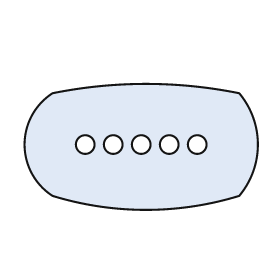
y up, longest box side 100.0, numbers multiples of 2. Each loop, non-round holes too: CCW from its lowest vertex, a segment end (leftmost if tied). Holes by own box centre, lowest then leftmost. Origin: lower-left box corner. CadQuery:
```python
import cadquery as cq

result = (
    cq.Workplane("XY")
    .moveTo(12.0, 6.0)
    .threePointArc((52.0, 0.0), (92.0, 6.0))
    .threePointArc((100.0, 28.0), (92.0, 50.0))
    .threePointArc((52.0, 54.0), (12.0, 50.0))
    .threePointArc((0.0, 28.0), (12.0, 6.0))
    .close()
    .moveTo(26.0, 28.0)
    .circle(4.0)
    .moveTo(38.0, 28.0)
    .circle(4.0)
    .moveTo(50.0, 28.0)
    .circle(4.0)
    .moveTo(62.0, 28.0)
    .circle(4.0)
    .moveTo(74.0, 28.0)
    .circle(4.0)
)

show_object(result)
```